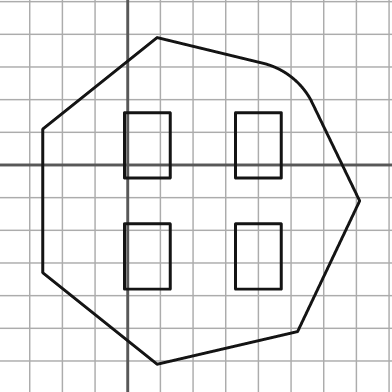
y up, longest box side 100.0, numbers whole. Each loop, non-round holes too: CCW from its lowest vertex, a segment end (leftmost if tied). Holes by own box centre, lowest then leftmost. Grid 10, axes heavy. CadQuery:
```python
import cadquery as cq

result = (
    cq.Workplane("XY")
    .moveTo(9.0, -61.0)
    .lineTo(52.0, -51.0)
    .lineTo(71.0, -11.0)
    .lineTo(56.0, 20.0)
    .threePointArc((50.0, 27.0), (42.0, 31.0))
    .lineTo(9.0, 39.0)
    .lineTo(-26.0, 11.0)
    .lineTo(-26.0, -33.0)
    .close()
    .moveTo(-1.0, -38.0)
    .lineTo(13.0, -38.0)
    .lineTo(13.0, -18.0)
    .lineTo(-1.0, -18.0)
    .close()
    .moveTo(33.0, -38.0)
    .lineTo(47.0, -38.0)
    .lineTo(47.0, -18.0)
    .lineTo(33.0, -18.0)
    .close()
    .moveTo(-1.0, -4.0)
    .lineTo(13.0, -4.0)
    .lineTo(13.0, 16.0)
    .lineTo(-1.0, 16.0)
    .close()
    .moveTo(33.0, -4.0)
    .lineTo(47.0, -4.0)
    .lineTo(47.0, 16.0)
    .lineTo(33.0, 16.0)
    .close()
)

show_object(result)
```